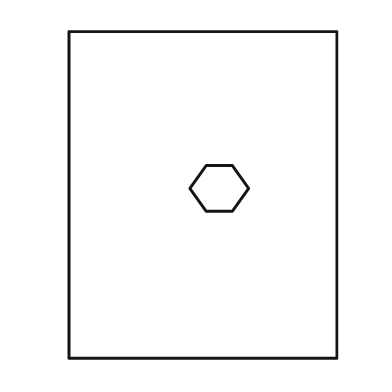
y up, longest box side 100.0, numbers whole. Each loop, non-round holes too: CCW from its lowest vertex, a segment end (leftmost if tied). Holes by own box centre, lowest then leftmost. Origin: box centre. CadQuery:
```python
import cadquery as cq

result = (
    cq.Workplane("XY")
    .moveTo(-41.0, -50.0)
    .lineTo(41.0, -50.0)
    .lineTo(41.0, 50.0)
    .lineTo(-41.0, 50.0)
    .close()
    .moveTo(1.0, -5.0)
    .lineTo(9.0, -5.0)
    .lineTo(14.0, 2.0)
    .lineTo(9.0, 9.0)
    .lineTo(1.0, 9.0)
    .lineTo(-4.0, 2.0)
    .close()
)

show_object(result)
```